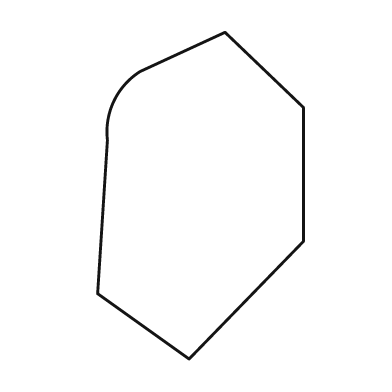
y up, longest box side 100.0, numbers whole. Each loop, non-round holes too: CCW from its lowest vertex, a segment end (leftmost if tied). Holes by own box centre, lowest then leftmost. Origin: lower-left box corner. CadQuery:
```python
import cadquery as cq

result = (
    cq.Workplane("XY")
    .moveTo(28.0, 0.0)
    .lineTo(63.0, 36.0)
    .lineTo(63.0, 77.0)
    .lineTo(39.0, 100.0)
    .lineTo(13.0, 88.0)
    .threePointArc((5.0, 79.0), (3.0, 67.0))
    .lineTo(0.0, 20.0)
    .close()
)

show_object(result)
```